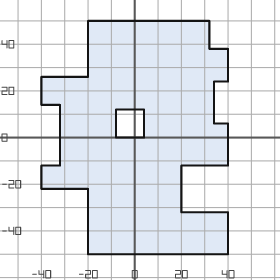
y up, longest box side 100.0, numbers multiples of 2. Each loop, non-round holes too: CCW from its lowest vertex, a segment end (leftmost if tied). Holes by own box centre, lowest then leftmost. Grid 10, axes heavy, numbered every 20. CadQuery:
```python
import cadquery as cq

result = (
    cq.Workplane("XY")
    .moveTo(-20.0, -50.0)
    .lineTo(40.0, -50.0)
    .lineTo(40.0, -32.0)
    .lineTo(20.0, -32.0)
    .lineTo(20.0, -12.0)
    .lineTo(40.0, -12.0)
    .lineTo(40.0, 6.0)
    .lineTo(34.0, 6.0)
    .lineTo(34.0, 24.0)
    .lineTo(40.0, 24.0)
    .lineTo(40.0, 38.0)
    .lineTo(32.0, 38.0)
    .lineTo(32.0, 50.0)
    .lineTo(-20.0, 50.0)
    .lineTo(-20.0, 26.0)
    .lineTo(-40.0, 26.0)
    .lineTo(-40.0, 14.0)
    .lineTo(-32.0, 14.0)
    .lineTo(-32.0, -12.0)
    .lineTo(-40.0, -12.0)
    .lineTo(-40.0, -22.0)
    .lineTo(-20.0, -22.0)
    .close()
    .moveTo(-8.0, 0.0)
    .lineTo(4.0, 0.0)
    .lineTo(4.0, 12.0)
    .lineTo(-8.0, 12.0)
    .close()
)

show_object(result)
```